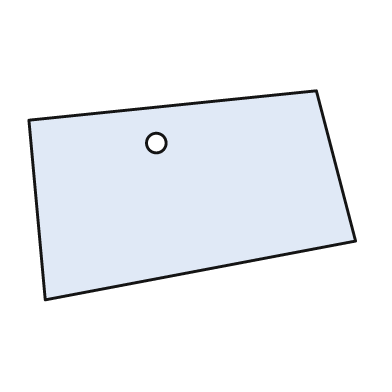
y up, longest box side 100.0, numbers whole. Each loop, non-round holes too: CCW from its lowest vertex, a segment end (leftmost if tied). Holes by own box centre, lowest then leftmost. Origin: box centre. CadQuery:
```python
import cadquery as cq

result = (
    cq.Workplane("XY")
    .moveTo(-45.0, -32.0)
    .lineTo(50.0, -14.0)
    .lineTo(38.0, 32.0)
    .lineTo(-50.0, 23.0)
    .close()
    .moveTo(-11.0, 16.0)
    .circle(3.0)
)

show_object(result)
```